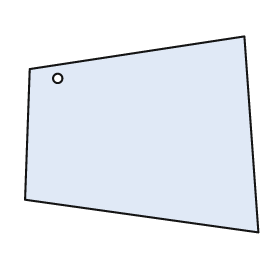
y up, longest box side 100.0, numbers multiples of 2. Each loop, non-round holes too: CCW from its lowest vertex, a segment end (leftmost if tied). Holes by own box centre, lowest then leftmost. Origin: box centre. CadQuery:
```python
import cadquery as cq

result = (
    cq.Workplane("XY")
    .moveTo(50.0, -42.0)
    .lineTo(44.0, 42.0)
    .lineTo(-48.0, 28.0)
    .lineTo(-50.0, -28.0)
    .close()
    .moveTo(-36.0, 24.0)
    .circle(2.0)
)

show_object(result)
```